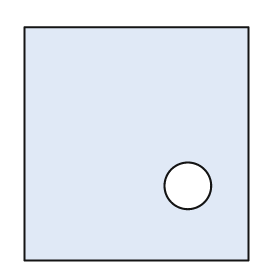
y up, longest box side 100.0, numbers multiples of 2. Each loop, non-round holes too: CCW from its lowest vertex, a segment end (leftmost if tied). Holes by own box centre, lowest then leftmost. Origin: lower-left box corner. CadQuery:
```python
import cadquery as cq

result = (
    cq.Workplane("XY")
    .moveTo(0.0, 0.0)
    .lineTo(96.0, 0.0)
    .lineTo(96.0, 100.0)
    .lineTo(0.0, 100.0)
    .close()
    .moveTo(70.0, 32.0)
    .circle(10.0)
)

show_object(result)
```